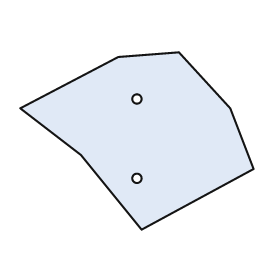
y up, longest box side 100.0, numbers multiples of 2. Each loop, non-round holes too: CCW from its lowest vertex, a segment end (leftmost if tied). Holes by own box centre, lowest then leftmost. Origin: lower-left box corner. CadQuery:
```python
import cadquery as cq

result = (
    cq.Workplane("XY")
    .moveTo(52.0, 0.0)
    .lineTo(100.0, 26.0)
    .lineTo(90.0, 52.0)
    .lineTo(68.0, 76.0)
    .lineTo(42.0, 74.0)
    .lineTo(0.0, 52.0)
    .lineTo(26.0, 32.0)
    .close()
    .moveTo(50.0, 22.0)
    .circle(2.0)
    .moveTo(50.0, 56.0)
    .circle(2.0)
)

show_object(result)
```